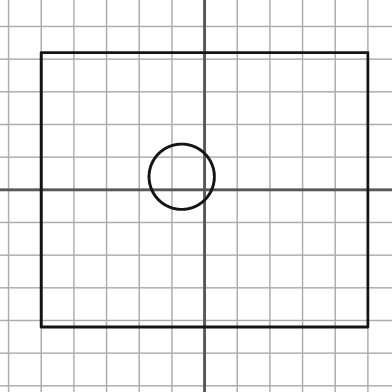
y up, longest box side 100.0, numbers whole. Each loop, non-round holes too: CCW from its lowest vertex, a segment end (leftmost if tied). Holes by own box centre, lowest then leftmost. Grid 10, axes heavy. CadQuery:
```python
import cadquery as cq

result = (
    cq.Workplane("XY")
    .moveTo(-50.0, -42.0)
    .lineTo(50.0, -42.0)
    .lineTo(50.0, 42.0)
    .lineTo(-50.0, 42.0)
    .close()
    .moveTo(-7.0, 4.0)
    .circle(10.0)
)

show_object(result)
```